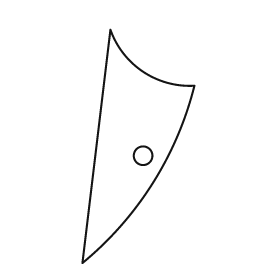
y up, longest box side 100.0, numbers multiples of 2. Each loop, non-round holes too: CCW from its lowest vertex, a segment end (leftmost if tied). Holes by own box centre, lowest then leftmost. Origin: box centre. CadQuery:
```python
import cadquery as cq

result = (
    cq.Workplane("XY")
    .moveTo(-24.0, -50.0)
    .threePointArc((6.0, -16.0), (24.0, 26.0))
    .threePointArc((2.0, 32.0), (-12.0, 50.0))
    .close()
    .moveTo(2.0, -4.0)
    .circle(4.0)
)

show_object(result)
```